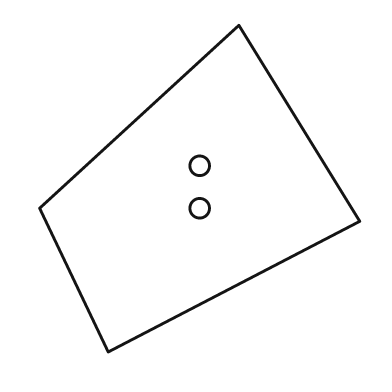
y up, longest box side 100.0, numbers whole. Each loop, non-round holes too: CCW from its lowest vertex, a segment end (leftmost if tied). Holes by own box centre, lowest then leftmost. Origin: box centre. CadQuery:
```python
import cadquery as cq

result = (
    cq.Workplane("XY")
    .moveTo(-28.0, -50.0)
    .lineTo(49.0, -10.0)
    .lineTo(12.0, 50.0)
    .lineTo(-49.0, -6.0)
    .close()
    .moveTo(0.0, -6.0)
    .circle(3.0)
    .moveTo(0.0, 7.0)
    .circle(3.0)
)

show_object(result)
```